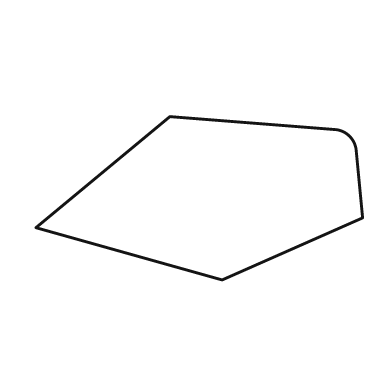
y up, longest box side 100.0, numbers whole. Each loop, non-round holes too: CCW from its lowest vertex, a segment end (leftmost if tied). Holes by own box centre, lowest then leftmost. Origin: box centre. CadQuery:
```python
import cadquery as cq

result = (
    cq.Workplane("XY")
    .moveTo(7.0, -25.0)
    .lineTo(50.0, -6.0)
    .lineTo(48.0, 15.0)
    .threePointArc((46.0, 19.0), (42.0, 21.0))
    .lineTo(-9.0, 25.0)
    .lineTo(-50.0, -9.0)
    .close()
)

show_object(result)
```